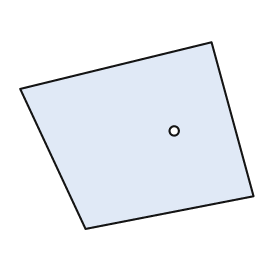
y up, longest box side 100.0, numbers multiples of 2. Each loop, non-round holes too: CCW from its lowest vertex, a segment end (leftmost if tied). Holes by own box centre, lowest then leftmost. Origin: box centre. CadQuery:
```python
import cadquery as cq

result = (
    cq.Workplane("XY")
    .moveTo(-22.0, -40.0)
    .lineTo(50.0, -26.0)
    .lineTo(32.0, 40.0)
    .lineTo(-50.0, 20.0)
    .close()
    .moveTo(16.0, 2.0)
    .circle(2.0)
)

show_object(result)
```